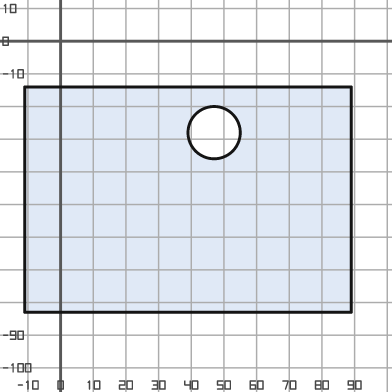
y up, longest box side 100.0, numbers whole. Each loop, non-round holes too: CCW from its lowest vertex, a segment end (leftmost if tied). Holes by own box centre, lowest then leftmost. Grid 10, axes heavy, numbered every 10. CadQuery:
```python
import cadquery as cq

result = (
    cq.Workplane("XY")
    .moveTo(-11.0, -83.0)
    .lineTo(89.0, -83.0)
    .lineTo(89.0, -14.0)
    .lineTo(-11.0, -14.0)
    .close()
    .moveTo(47.0, -28.0)
    .circle(8.0)
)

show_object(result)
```